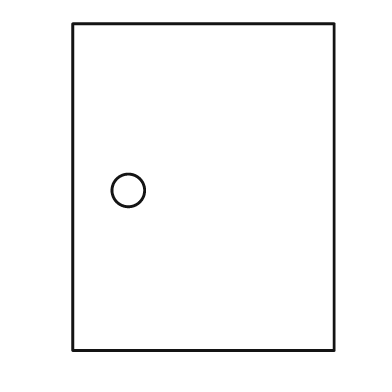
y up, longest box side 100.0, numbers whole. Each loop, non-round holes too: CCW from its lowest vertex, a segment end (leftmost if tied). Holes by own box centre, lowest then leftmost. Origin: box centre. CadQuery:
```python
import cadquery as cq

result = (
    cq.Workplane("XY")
    .moveTo(-40.0, -50.0)
    .lineTo(40.0, -50.0)
    .lineTo(40.0, 50.0)
    .lineTo(-40.0, 50.0)
    .close()
    .moveTo(-23.0, -1.0)
    .circle(5.0)
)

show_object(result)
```